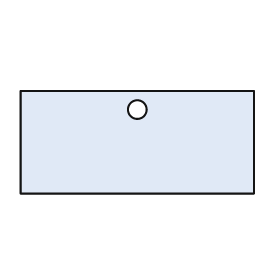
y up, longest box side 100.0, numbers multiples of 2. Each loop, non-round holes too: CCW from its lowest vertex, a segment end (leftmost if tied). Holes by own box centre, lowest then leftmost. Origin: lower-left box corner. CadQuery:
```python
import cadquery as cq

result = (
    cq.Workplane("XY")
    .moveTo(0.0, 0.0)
    .lineTo(100.0, 0.0)
    .lineTo(100.0, 44.0)
    .lineTo(0.0, 44.0)
    .close()
    .moveTo(50.0, 36.0)
    .circle(4.0)
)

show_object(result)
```